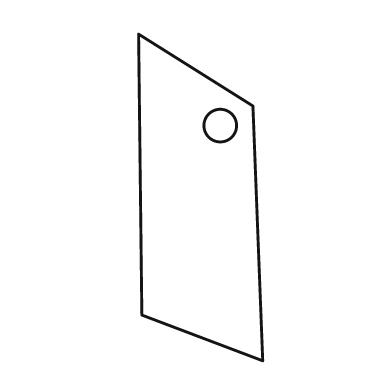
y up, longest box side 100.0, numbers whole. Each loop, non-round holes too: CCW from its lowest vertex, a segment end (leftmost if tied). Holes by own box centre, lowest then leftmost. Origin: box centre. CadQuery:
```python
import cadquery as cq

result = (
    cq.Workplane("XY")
    .moveTo(19.0, -50.0)
    .lineTo(16.0, 28.0)
    .lineTo(-19.0, 50.0)
    .lineTo(-18.0, -36.0)
    .close()
    .moveTo(6.0, 22.0)
    .circle(5.0)
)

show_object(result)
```